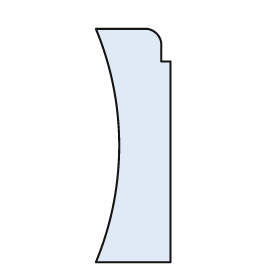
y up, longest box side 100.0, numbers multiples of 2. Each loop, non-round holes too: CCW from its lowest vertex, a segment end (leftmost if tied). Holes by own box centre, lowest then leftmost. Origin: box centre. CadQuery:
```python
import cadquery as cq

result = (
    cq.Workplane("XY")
    .moveTo(-16.0, -50.0)
    .lineTo(16.0, -50.0)
    .lineTo(16.0, 36.0)
    .lineTo(12.0, 36.0)
    .lineTo(12.0, 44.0)
    .threePointArc((10.0, 48.0), (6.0, 50.0))
    .lineTo(-16.0, 50.0)
    .threePointArc((-6.0, 0.0), (-16.0, -50.0))
    .close()
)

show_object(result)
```